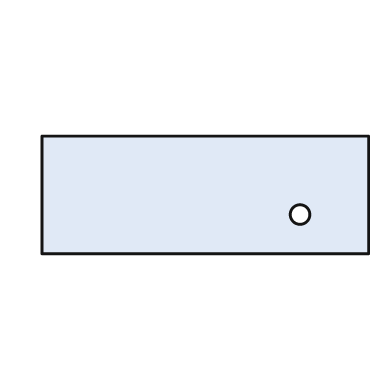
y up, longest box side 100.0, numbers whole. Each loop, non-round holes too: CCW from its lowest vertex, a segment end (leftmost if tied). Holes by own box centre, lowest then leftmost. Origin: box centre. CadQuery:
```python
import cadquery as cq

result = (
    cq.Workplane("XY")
    .moveTo(-50.0, -18.0)
    .lineTo(50.0, -18.0)
    .lineTo(50.0, 18.0)
    .lineTo(-50.0, 18.0)
    .close()
    .moveTo(29.0, -6.0)
    .circle(3.0)
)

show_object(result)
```